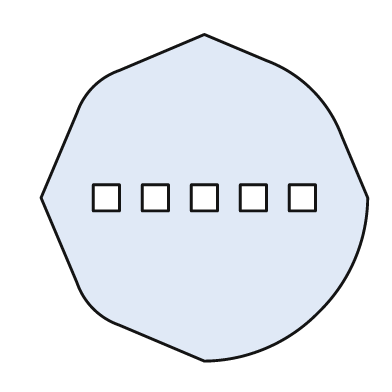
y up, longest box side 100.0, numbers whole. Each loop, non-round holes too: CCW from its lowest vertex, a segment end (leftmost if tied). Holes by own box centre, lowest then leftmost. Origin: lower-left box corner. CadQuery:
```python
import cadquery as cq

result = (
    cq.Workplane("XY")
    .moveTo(50.0, 0.0)
    .threePointArc((69.0, 4.0), (85.0, 15.0))
    .threePointArc((96.0, 31.0), (100.0, 50.0))
    .lineTo(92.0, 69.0)
    .threePointArc((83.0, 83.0), (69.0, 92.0))
    .lineTo(50.0, 100.0)
    .lineTo(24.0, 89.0)
    .threePointArc((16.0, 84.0), (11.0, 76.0))
    .lineTo(0.0, 50.0)
    .lineTo(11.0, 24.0)
    .threePointArc((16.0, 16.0), (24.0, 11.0))
    .close()
    .moveTo(16.0, 46.0)
    .lineTo(24.0, 46.0)
    .lineTo(24.0, 54.0)
    .lineTo(16.0, 54.0)
    .close()
    .moveTo(31.0, 46.0)
    .lineTo(39.0, 46.0)
    .lineTo(39.0, 54.0)
    .lineTo(31.0, 54.0)
    .close()
    .moveTo(46.0, 46.0)
    .lineTo(54.0, 46.0)
    .lineTo(54.0, 54.0)
    .lineTo(46.0, 54.0)
    .close()
    .moveTo(61.0, 46.0)
    .lineTo(69.0, 46.0)
    .lineTo(69.0, 54.0)
    .lineTo(61.0, 54.0)
    .close()
    .moveTo(76.0, 46.0)
    .lineTo(84.0, 46.0)
    .lineTo(84.0, 54.0)
    .lineTo(76.0, 54.0)
    .close()
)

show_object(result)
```